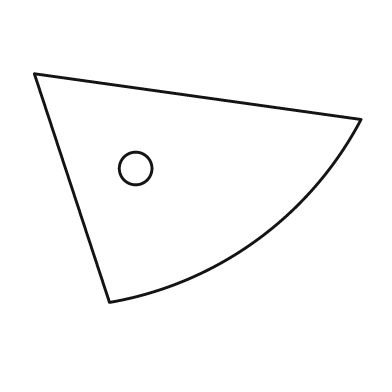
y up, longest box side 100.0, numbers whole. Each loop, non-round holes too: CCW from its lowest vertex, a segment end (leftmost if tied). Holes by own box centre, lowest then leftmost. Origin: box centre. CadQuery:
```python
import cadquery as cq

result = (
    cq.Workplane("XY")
    .moveTo(-27.0, -35.0)
    .threePointArc((18.0, -16.0), (50.0, 21.0))
    .lineTo(-50.0, 35.0)
    .close()
    .moveTo(-19.0, 6.0)
    .circle(5.0)
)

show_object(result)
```